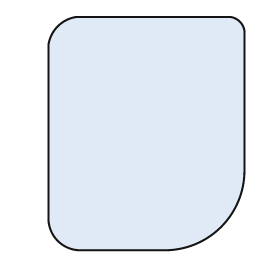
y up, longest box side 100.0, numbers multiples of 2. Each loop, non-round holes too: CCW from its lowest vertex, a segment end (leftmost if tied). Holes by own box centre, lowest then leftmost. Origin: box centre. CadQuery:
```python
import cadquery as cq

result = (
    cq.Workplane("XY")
    .moveTo(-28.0, -50.0)
    .lineTo(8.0, -50.0)
    .threePointArc((32.0, -40.0), (42.0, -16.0))
    .lineTo(42.0, 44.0)
    .threePointArc((40.0, 48.0), (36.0, 50.0))
    .lineTo(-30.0, 50.0)
    .threePointArc((-38.0, 46.0), (-42.0, 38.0))
    .lineTo(-42.0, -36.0)
    .threePointArc((-38.0, -46.0), (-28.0, -50.0))
    .close()
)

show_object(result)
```